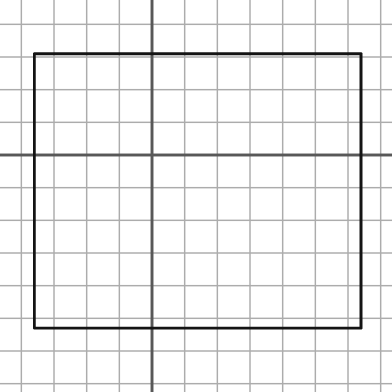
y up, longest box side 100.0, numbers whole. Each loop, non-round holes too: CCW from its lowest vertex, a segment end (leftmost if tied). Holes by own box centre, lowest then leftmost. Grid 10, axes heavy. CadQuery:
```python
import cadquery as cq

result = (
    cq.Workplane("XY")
    .moveTo(-36.0, -53.0)
    .lineTo(64.0, -53.0)
    .lineTo(64.0, 31.0)
    .lineTo(-36.0, 31.0)
    .close()
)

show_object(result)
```